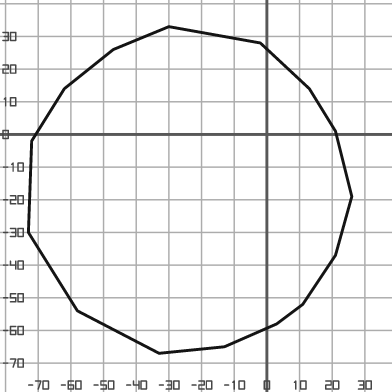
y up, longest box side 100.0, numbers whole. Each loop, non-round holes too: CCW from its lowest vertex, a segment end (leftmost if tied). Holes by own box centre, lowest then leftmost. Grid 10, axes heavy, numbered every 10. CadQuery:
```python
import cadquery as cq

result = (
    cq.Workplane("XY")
    .moveTo(-33.0, -67.0)
    .lineTo(-13.0, -65.0)
    .lineTo(3.0, -58.0)
    .lineTo(11.0, -52.0)
    .lineTo(21.0, -37.0)
    .lineTo(26.0, -19.0)
    .lineTo(21.0, 1.0)
    .lineTo(13.0, 14.0)
    .lineTo(-2.0, 28.0)
    .lineTo(-30.0, 33.0)
    .lineTo(-47.0, 26.0)
    .lineTo(-62.0, 14.0)
    .lineTo(-72.0, -2.0)
    .lineTo(-73.0, -30.0)
    .lineTo(-58.0, -54.0)
    .close()
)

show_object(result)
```